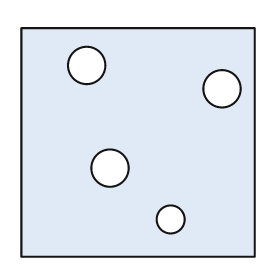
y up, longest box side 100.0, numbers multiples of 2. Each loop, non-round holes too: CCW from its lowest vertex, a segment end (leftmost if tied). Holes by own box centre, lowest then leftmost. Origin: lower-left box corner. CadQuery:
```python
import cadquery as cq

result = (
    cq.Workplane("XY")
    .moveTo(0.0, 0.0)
    .lineTo(100.0, 0.0)
    .lineTo(100.0, 98.0)
    .lineTo(0.0, 98.0)
    .close()
    .moveTo(64.0, 16.0)
    .circle(6.0)
    .moveTo(38.0, 38.0)
    .circle(8.0)
    .moveTo(86.0, 72.0)
    .circle(8.0)
    .moveTo(28.0, 82.0)
    .circle(8.0)
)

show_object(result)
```